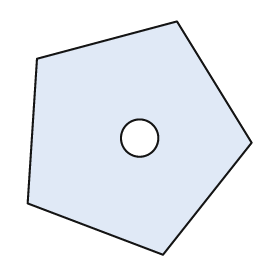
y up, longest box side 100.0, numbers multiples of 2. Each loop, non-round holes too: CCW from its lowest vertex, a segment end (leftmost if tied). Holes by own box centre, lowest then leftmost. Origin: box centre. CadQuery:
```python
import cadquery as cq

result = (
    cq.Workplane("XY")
    .moveTo(10.0, -50.0)
    .lineTo(48.0, -2.0)
    .lineTo(16.0, 50.0)
    .lineTo(-44.0, 34.0)
    .lineTo(-48.0, -28.0)
    .close()
    .moveTo(0.0, 0.0)
    .circle(8.0)
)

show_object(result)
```